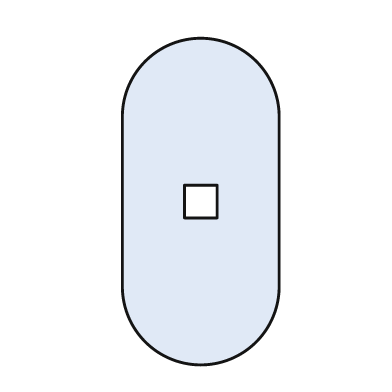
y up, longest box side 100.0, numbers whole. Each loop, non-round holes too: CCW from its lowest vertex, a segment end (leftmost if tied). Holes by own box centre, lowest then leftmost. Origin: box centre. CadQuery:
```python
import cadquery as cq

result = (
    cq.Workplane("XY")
    .moveTo(-24.0, -26.0)
    .threePointArc((0.0, -50.0), (24.0, -26.0))
    .lineTo(24.0, 26.0)
    .threePointArc((0.0, 50.0), (-24.0, 26.0))
    .close()
    .moveTo(-5.0, -5.0)
    .lineTo(5.0, -5.0)
    .lineTo(5.0, 5.0)
    .lineTo(-5.0, 5.0)
    .close()
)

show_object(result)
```